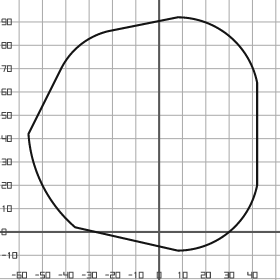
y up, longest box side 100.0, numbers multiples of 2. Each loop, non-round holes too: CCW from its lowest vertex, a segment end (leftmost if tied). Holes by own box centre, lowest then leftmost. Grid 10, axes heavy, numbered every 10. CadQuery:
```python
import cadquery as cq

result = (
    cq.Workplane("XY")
    .moveTo(8.0, -8.0)
    .threePointArc((30.0, 0.0), (42.0, 20.0))
    .lineTo(42.0, 64.0)
    .threePointArc((30.0, 84.0), (8.0, 92.0))
    .lineTo(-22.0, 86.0)
    .threePointArc((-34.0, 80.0), (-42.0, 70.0))
    .lineTo(-56.0, 42.0)
    .threePointArc((-50.0, 20.0), (-36.0, 2.0))
    .close()
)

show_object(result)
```